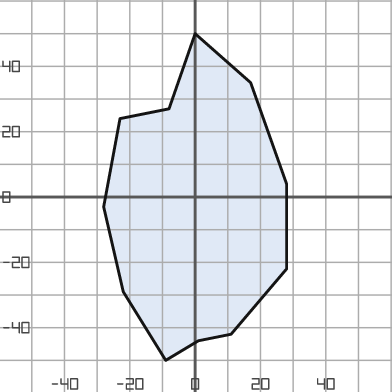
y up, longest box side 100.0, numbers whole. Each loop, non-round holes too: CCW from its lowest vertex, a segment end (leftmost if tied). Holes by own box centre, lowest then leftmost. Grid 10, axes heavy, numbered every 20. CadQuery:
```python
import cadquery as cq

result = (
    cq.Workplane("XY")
    .moveTo(-9.0, -50.0)
    .lineTo(1.0, -44.0)
    .lineTo(11.0, -42.0)
    .lineTo(28.0, -22.0)
    .lineTo(28.0, 4.0)
    .lineTo(17.0, 35.0)
    .lineTo(0.0, 50.0)
    .lineTo(-8.0, 27.0)
    .lineTo(-23.0, 24.0)
    .lineTo(-28.0, -3.0)
    .lineTo(-22.0, -29.0)
    .close()
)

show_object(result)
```